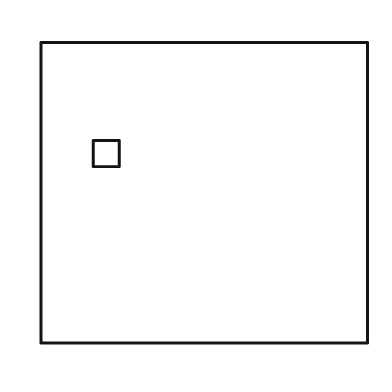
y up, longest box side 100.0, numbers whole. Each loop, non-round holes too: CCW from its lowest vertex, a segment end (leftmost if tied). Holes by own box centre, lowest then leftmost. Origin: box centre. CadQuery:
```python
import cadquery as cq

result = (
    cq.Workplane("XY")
    .moveTo(-50.0, -46.0)
    .lineTo(50.0, -46.0)
    .lineTo(50.0, 46.0)
    .lineTo(-50.0, 46.0)
    .close()
    .moveTo(-34.0, 8.0)
    .lineTo(-26.0, 8.0)
    .lineTo(-26.0, 16.0)
    .lineTo(-34.0, 16.0)
    .close()
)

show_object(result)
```